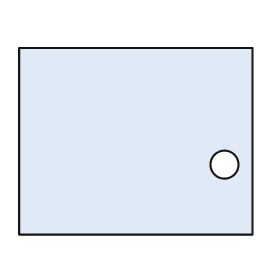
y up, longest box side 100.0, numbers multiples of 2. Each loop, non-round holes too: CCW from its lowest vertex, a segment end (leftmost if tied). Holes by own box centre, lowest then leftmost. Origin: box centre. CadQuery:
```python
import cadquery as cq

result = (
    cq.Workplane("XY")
    .moveTo(-50.0, -40.0)
    .lineTo(50.0, -40.0)
    .lineTo(50.0, 40.0)
    .lineTo(-50.0, 40.0)
    .close()
    .moveTo(38.0, -10.0)
    .circle(6.0)
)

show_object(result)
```